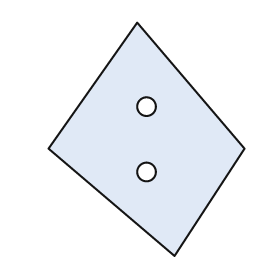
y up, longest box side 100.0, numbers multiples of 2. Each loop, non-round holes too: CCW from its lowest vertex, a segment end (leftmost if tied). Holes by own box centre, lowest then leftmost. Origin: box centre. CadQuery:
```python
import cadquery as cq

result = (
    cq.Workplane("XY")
    .moveTo(12.0, -50.0)
    .lineTo(42.0, -4.0)
    .lineTo(-4.0, 50.0)
    .lineTo(-42.0, -4.0)
    .close()
    .moveTo(0.0, -14.0)
    .circle(4.0)
    .moveTo(0.0, 14.0)
    .circle(4.0)
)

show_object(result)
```